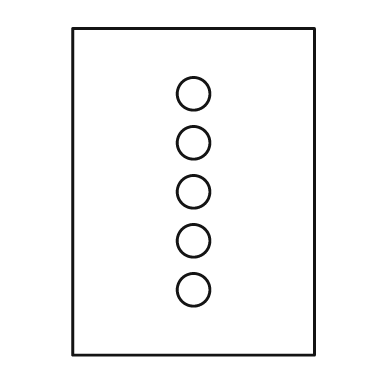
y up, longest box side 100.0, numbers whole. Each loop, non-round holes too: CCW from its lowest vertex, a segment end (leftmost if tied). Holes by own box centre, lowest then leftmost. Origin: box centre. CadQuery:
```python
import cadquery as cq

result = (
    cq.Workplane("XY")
    .moveTo(-37.0, -50.0)
    .lineTo(37.0, -50.0)
    .lineTo(37.0, 50.0)
    .lineTo(-37.0, 50.0)
    .close()
    .moveTo(0.0, -30.0)
    .circle(5.0)
    .moveTo(0.0, -15.0)
    .circle(5.0)
    .moveTo(0.0, 0.0)
    .circle(5.0)
    .moveTo(0.0, 15.0)
    .circle(5.0)
    .moveTo(0.0, 30.0)
    .circle(5.0)
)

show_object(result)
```